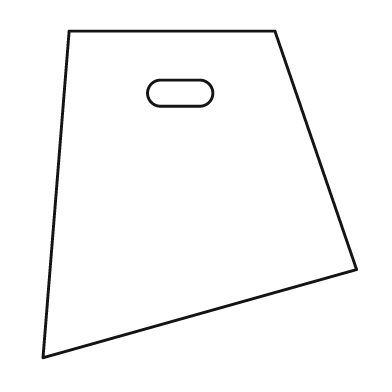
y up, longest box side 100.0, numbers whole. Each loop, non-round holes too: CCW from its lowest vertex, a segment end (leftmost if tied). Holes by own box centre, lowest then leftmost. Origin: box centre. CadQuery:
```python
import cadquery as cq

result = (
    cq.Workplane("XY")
    .moveTo(-48.0, -50.0)
    .lineTo(48.0, -23.0)
    .lineTo(23.0, 50.0)
    .lineTo(-40.0, 50.0)
    .close()
    .moveTo(-12.0, 27.0)
    .lineTo(0.0, 27.0)
    .threePointArc((4.0, 31.0), (0.0, 35.0))
    .lineTo(-12.0, 35.0)
    .threePointArc((-16.0, 31.0), (-12.0, 27.0))
    .close()
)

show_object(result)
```